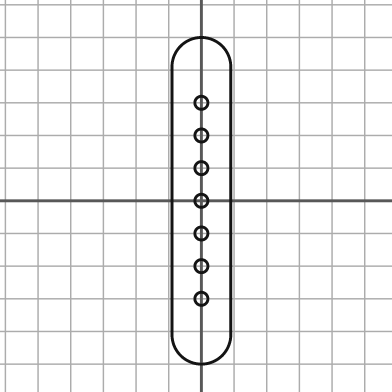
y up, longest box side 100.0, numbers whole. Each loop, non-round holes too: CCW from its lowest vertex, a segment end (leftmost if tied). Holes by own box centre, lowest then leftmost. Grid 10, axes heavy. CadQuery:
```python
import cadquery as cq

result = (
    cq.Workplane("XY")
    .moveTo(-9.0, -41.0)
    .threePointArc((0.0, -50.0), (9.0, -41.0))
    .lineTo(9.0, 41.0)
    .threePointArc((0.0, 50.0), (-9.0, 41.0))
    .close()
    .moveTo(0.0, -30.0)
    .circle(2.0)
    .moveTo(0.0, -20.0)
    .circle(2.0)
    .moveTo(0.0, -10.0)
    .circle(2.0)
    .moveTo(0.0, 0.0)
    .circle(2.0)
    .moveTo(0.0, 10.0)
    .circle(2.0)
    .moveTo(0.0, 20.0)
    .circle(2.0)
    .moveTo(0.0, 30.0)
    .circle(2.0)
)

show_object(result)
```